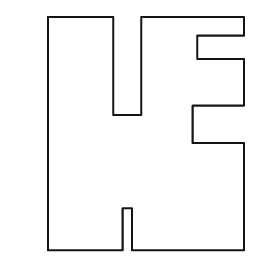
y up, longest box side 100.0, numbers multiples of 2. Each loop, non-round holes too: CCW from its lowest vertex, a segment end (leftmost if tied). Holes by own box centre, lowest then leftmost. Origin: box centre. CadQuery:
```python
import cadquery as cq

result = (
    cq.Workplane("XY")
    .moveTo(-42.0, -50.0)
    .lineTo(-10.0, -50.0)
    .lineTo(-10.0, -32.0)
    .lineTo(-6.0, -32.0)
    .lineTo(-6.0, -50.0)
    .lineTo(42.0, -50.0)
    .lineTo(42.0, -4.0)
    .lineTo(20.0, -4.0)
    .lineTo(20.0, 12.0)
    .lineTo(42.0, 12.0)
    .lineTo(42.0, 32.0)
    .lineTo(22.0, 32.0)
    .lineTo(22.0, 42.0)
    .lineTo(42.0, 42.0)
    .lineTo(42.0, 50.0)
    .lineTo(-2.0, 50.0)
    .lineTo(-2.0, 8.0)
    .lineTo(-14.0, 8.0)
    .lineTo(-14.0, 50.0)
    .lineTo(-42.0, 50.0)
    .close()
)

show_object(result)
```